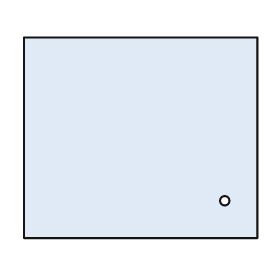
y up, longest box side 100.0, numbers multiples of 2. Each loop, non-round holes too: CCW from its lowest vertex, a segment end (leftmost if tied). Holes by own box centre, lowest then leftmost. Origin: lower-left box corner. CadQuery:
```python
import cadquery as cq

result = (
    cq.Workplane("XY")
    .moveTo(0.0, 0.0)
    .lineTo(100.0, 0.0)
    .lineTo(100.0, 86.0)
    .lineTo(0.0, 86.0)
    .close()
    .moveTo(86.0, 16.0)
    .circle(2.0)
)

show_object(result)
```